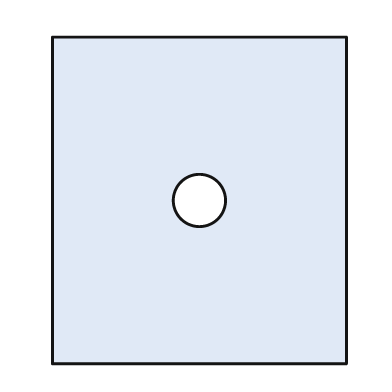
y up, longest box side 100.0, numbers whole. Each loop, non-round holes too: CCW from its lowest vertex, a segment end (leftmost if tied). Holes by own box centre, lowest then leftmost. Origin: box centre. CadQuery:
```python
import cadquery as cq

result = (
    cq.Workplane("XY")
    .moveTo(-45.0, -50.0)
    .lineTo(45.0, -50.0)
    .lineTo(45.0, 50.0)
    .lineTo(-45.0, 50.0)
    .close()
    .moveTo(0.0, 0.0)
    .circle(8.0)
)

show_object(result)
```